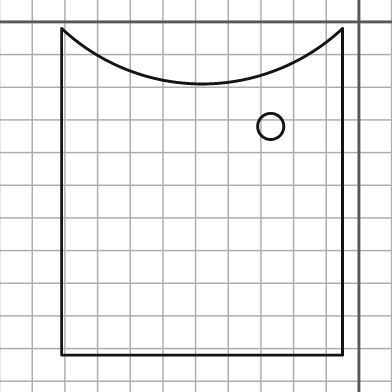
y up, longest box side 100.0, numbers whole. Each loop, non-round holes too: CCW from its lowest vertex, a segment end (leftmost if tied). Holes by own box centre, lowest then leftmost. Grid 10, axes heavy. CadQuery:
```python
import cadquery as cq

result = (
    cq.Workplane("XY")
    .moveTo(-91.0, -102.0)
    .lineTo(-5.0, -102.0)
    .lineTo(-5.0, -2.0)
    .threePointArc((-48.0, -19.0), (-91.0, -2.0))
    .close()
    .moveTo(-27.0, -32.0)
    .circle(4.0)
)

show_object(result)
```